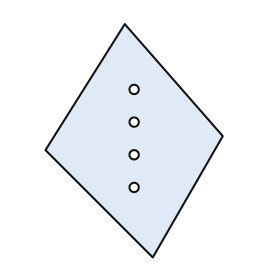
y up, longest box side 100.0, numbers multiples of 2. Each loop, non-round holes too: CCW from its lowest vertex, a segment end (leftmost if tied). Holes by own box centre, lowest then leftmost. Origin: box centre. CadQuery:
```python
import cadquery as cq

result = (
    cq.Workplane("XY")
    .moveTo(8.0, -50.0)
    .lineTo(38.0, 2.0)
    .lineTo(-4.0, 50.0)
    .lineTo(-38.0, -4.0)
    .close()
    .moveTo(0.0, -20.0)
    .circle(2.0)
    .moveTo(0.0, -6.0)
    .circle(2.0)
    .moveTo(0.0, 8.0)
    .circle(2.0)
    .moveTo(0.0, 22.0)
    .circle(2.0)
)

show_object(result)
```